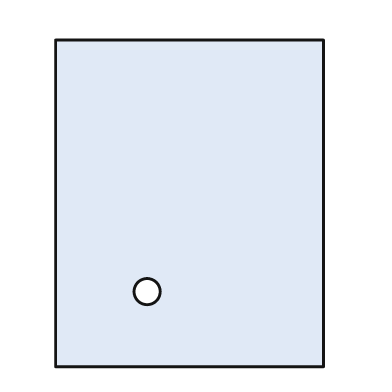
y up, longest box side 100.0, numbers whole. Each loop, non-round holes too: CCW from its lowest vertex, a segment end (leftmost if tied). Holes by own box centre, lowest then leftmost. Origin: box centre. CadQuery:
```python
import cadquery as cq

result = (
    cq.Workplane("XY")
    .moveTo(-41.0, -50.0)
    .lineTo(41.0, -50.0)
    .lineTo(41.0, 50.0)
    .lineTo(-41.0, 50.0)
    .close()
    .moveTo(-13.0, -27.0)
    .circle(4.0)
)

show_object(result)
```